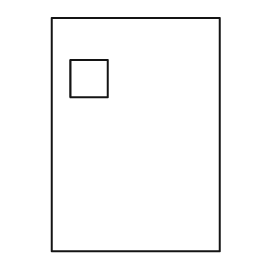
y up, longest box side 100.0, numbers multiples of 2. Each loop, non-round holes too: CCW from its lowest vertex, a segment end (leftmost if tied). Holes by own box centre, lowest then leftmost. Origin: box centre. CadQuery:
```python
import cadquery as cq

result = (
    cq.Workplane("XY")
    .moveTo(-36.0, -50.0)
    .lineTo(36.0, -50.0)
    .lineTo(36.0, 50.0)
    .lineTo(-36.0, 50.0)
    .close()
    .moveTo(-28.0, 16.0)
    .lineTo(-12.0, 16.0)
    .lineTo(-12.0, 32.0)
    .lineTo(-28.0, 32.0)
    .close()
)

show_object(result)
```